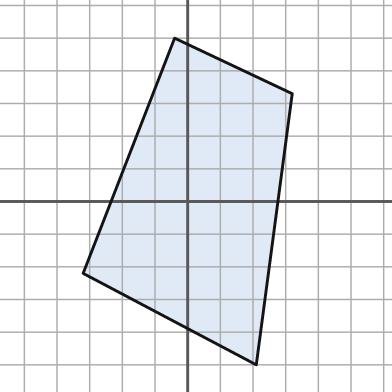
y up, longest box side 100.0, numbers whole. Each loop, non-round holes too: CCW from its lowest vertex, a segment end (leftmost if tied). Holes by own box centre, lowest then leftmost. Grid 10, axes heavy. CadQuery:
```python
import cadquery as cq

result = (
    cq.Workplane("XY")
    .moveTo(21.0, -50.0)
    .lineTo(32.0, 33.0)
    .lineTo(-4.0, 50.0)
    .lineTo(-32.0, -22.0)
    .close()
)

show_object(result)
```